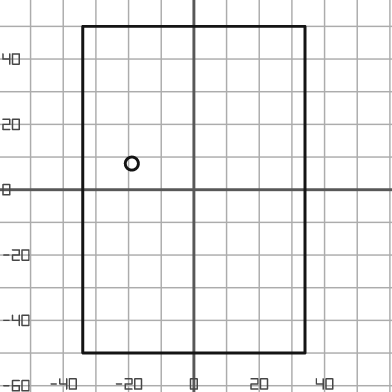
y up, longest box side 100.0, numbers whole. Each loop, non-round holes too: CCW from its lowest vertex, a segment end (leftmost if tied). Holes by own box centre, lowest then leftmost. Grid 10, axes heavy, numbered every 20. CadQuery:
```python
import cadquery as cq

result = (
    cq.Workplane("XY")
    .moveTo(-34.0, -50.0)
    .lineTo(34.0, -50.0)
    .lineTo(34.0, 50.0)
    .lineTo(-34.0, 50.0)
    .close()
    .moveTo(-19.0, 8.0)
    .circle(2.0)
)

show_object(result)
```